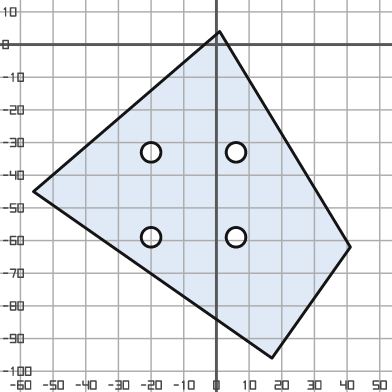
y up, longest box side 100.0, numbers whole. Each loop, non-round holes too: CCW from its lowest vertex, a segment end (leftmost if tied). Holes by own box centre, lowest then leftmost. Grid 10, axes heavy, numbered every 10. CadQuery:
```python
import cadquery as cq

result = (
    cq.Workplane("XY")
    .moveTo(17.0, -96.0)
    .lineTo(41.0, -62.0)
    .lineTo(1.0, 4.0)
    .lineTo(-56.0, -45.0)
    .close()
    .moveTo(-20.0, -59.0)
    .circle(3.0)
    .moveTo(6.0, -59.0)
    .circle(3.0)
    .moveTo(-20.0, -33.0)
    .circle(3.0)
    .moveTo(6.0, -33.0)
    .circle(3.0)
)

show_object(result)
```